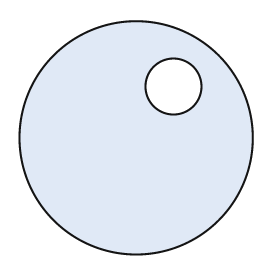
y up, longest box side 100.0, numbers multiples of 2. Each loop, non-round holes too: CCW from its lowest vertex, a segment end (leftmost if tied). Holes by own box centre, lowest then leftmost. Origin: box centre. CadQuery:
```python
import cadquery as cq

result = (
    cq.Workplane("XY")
    .moveTo(0.0, 0.0)
    .circle(50.0)
    .moveTo(16.0, 22.0)
    .circle(12.0)
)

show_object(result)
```